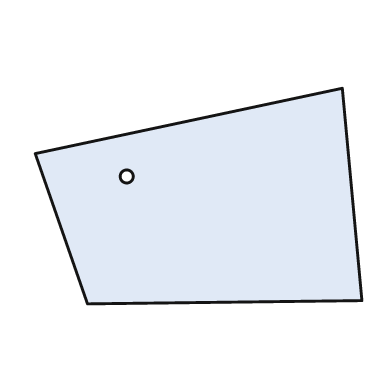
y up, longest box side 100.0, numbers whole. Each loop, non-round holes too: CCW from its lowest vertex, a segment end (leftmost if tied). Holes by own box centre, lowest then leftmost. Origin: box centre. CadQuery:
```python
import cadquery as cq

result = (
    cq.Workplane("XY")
    .moveTo(-34.0, -33.0)
    .lineTo(50.0, -32.0)
    .lineTo(44.0, 33.0)
    .lineTo(-50.0, 13.0)
    .close()
    .moveTo(-22.0, 6.0)
    .circle(2.0)
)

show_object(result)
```